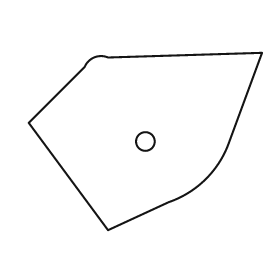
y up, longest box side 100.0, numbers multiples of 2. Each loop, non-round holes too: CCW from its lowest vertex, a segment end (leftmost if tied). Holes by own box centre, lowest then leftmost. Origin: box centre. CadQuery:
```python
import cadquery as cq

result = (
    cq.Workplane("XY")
    .moveTo(-16.0, -38.0)
    .lineTo(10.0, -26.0)
    .threePointArc((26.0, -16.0), (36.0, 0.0))
    .lineTo(50.0, 38.0)
    .lineTo(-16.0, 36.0)
    .threePointArc((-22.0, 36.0), (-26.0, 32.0))
    .lineTo(-50.0, 8.0)
    .close()
    .moveTo(0.0, 0.0)
    .circle(4.0)
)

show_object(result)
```